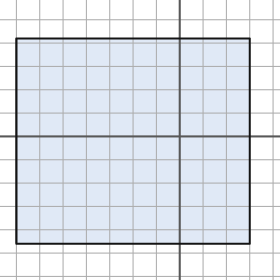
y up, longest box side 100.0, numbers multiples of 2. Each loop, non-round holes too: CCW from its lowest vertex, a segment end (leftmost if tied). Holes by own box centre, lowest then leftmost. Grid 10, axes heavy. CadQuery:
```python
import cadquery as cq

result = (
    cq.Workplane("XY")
    .moveTo(-70.0, -46.0)
    .lineTo(30.0, -46.0)
    .lineTo(30.0, 42.0)
    .lineTo(-70.0, 42.0)
    .close()
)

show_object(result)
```